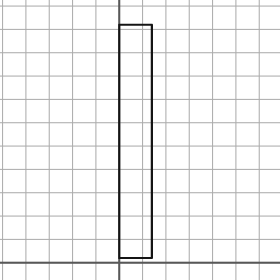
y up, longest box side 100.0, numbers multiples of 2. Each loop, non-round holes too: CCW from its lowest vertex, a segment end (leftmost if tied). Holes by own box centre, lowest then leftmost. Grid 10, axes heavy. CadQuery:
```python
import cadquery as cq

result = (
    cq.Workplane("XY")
    .moveTo(0.0, 2.0)
    .lineTo(14.0, 2.0)
    .lineTo(14.0, 102.0)
    .lineTo(0.0, 102.0)
    .close()
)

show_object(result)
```